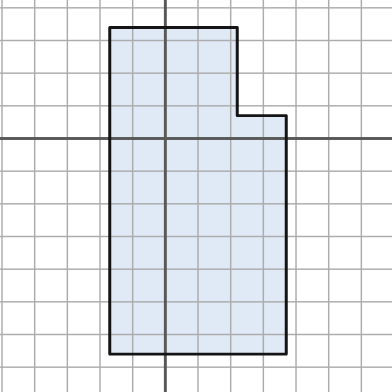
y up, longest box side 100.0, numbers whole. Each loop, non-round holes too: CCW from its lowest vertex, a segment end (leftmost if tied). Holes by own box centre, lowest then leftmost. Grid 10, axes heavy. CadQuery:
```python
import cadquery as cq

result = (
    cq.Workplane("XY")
    .moveTo(-17.0, -66.0)
    .lineTo(37.0, -66.0)
    .lineTo(37.0, 7.0)
    .lineTo(22.0, 7.0)
    .lineTo(22.0, 34.0)
    .lineTo(-17.0, 34.0)
    .close()
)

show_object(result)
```